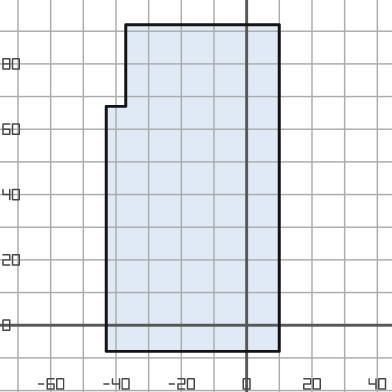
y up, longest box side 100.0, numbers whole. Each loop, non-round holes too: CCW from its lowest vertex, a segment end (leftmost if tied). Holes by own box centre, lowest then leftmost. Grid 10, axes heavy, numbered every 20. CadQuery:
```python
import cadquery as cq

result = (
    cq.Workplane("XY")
    .moveTo(-43.0, -8.0)
    .lineTo(10.0, -8.0)
    .lineTo(10.0, 92.0)
    .lineTo(-37.0, 92.0)
    .lineTo(-37.0, 67.0)
    .lineTo(-43.0, 67.0)
    .close()
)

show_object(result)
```